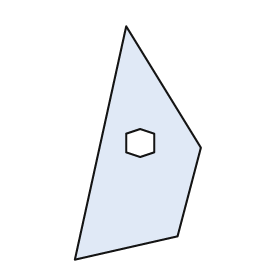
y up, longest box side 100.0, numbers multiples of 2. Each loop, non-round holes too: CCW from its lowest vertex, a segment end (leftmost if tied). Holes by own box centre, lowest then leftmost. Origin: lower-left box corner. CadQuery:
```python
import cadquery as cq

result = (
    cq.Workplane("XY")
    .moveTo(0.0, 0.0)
    .lineTo(44.0, 10.0)
    .lineTo(54.0, 48.0)
    .lineTo(22.0, 100.0)
    .close()
    .moveTo(28.0, 44.0)
    .lineTo(34.0, 46.0)
    .lineTo(34.0, 54.0)
    .lineTo(28.0, 56.0)
    .lineTo(22.0, 54.0)
    .lineTo(22.0, 46.0)
    .close()
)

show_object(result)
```